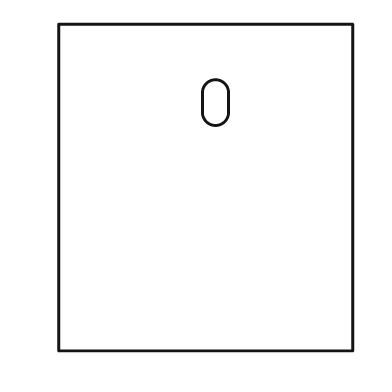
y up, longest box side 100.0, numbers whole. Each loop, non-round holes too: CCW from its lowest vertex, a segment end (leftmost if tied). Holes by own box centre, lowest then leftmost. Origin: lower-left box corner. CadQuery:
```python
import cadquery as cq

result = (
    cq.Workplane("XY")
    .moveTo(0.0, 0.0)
    .lineTo(90.0, 0.0)
    .lineTo(90.0, 100.0)
    .lineTo(0.0, 100.0)
    .close()
    .moveTo(44.0, 73.0)
    .threePointArc((48.0, 69.0), (52.0, 73.0))
    .lineTo(52.0, 79.0)
    .threePointArc((48.0, 83.0), (44.0, 79.0))
    .close()
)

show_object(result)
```